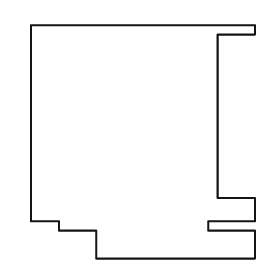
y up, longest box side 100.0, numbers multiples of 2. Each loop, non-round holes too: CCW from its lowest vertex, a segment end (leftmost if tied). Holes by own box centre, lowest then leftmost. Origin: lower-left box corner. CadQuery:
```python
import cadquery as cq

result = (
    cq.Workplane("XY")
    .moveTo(28.0, 0.0)
    .lineTo(96.0, 0.0)
    .lineTo(96.0, 12.0)
    .lineTo(76.0, 12.0)
    .lineTo(76.0, 16.0)
    .lineTo(96.0, 16.0)
    .lineTo(96.0, 26.0)
    .lineTo(80.0, 26.0)
    .lineTo(80.0, 96.0)
    .lineTo(96.0, 96.0)
    .lineTo(96.0, 100.0)
    .lineTo(0.0, 100.0)
    .lineTo(0.0, 16.0)
    .lineTo(12.0, 16.0)
    .lineTo(12.0, 12.0)
    .lineTo(28.0, 12.0)
    .close()
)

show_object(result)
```